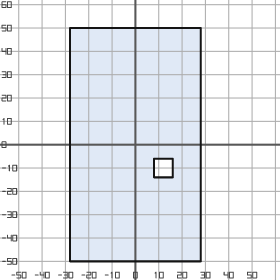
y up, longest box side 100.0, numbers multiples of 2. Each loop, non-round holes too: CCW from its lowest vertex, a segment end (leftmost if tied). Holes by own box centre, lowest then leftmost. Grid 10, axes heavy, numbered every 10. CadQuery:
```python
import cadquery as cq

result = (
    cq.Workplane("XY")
    .moveTo(-28.0, -50.0)
    .lineTo(28.0, -50.0)
    .lineTo(28.0, 50.0)
    .lineTo(-28.0, 50.0)
    .close()
    .moveTo(8.0, -14.0)
    .lineTo(16.0, -14.0)
    .lineTo(16.0, -6.0)
    .lineTo(8.0, -6.0)
    .close()
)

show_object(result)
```